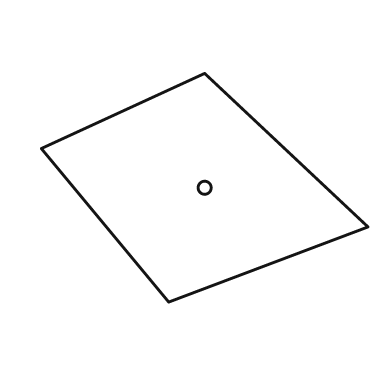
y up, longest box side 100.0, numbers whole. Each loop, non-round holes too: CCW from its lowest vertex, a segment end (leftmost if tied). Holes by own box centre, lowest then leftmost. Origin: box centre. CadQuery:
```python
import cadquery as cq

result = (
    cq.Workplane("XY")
    .moveTo(-11.0, -35.0)
    .lineTo(50.0, -12.0)
    .lineTo(0.0, 35.0)
    .lineTo(-50.0, 12.0)
    .close()
    .moveTo(0.0, 0.0)
    .circle(2.0)
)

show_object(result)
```